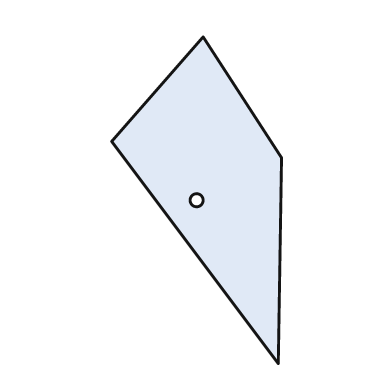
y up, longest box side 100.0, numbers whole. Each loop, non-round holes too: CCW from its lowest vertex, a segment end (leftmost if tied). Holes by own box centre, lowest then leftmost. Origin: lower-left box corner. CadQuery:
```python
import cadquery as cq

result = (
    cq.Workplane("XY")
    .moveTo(51.0, 0.0)
    .lineTo(52.0, 63.0)
    .lineTo(28.0, 100.0)
    .lineTo(0.0, 68.0)
    .close()
    .moveTo(26.0, 50.0)
    .circle(2.0)
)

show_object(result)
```